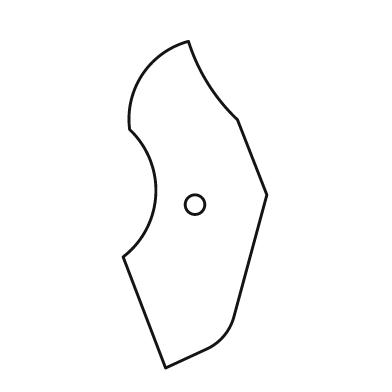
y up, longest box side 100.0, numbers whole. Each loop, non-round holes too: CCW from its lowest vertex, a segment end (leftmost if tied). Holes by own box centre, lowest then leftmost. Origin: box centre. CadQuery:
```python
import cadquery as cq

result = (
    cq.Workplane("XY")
    .moveTo(-9.0, -50.0)
    .lineTo(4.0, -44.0)
    .threePointArc((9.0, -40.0), (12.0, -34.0))
    .lineTo(22.0, 3.0)
    .lineTo(13.0, 26.0)
    .threePointArc((4.0, 37.0), (-2.0, 50.0))
    .threePointArc((-16.0, 40.0), (-20.0, 23.0))
    .threePointArc((-12.0, 3.0), (-22.0, -16.0))
    .close()
    .moveTo(0.0, 0.0)
    .circle(3.0)
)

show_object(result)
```